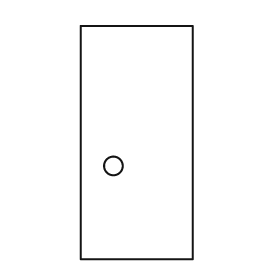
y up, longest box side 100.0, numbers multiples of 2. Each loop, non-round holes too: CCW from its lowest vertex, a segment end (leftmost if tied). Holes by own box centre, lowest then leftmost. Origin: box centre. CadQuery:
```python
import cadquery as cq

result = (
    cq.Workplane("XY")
    .moveTo(-24.0, -50.0)
    .lineTo(24.0, -50.0)
    .lineTo(24.0, 50.0)
    .lineTo(-24.0, 50.0)
    .close()
    .moveTo(-10.0, -10.0)
    .circle(4.0)
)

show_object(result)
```